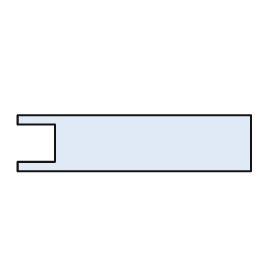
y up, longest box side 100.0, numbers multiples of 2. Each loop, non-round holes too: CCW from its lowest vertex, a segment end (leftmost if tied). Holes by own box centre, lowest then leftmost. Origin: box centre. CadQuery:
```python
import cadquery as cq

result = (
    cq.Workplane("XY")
    .moveTo(-50.0, -12.0)
    .lineTo(50.0, -12.0)
    .lineTo(50.0, 12.0)
    .lineTo(-50.0, 12.0)
    .lineTo(-50.0, 8.0)
    .lineTo(-34.0, 8.0)
    .lineTo(-34.0, -8.0)
    .lineTo(-50.0, -8.0)
    .close()
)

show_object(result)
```